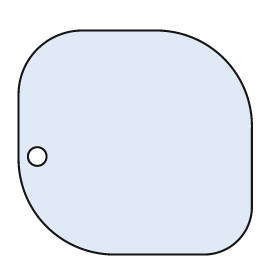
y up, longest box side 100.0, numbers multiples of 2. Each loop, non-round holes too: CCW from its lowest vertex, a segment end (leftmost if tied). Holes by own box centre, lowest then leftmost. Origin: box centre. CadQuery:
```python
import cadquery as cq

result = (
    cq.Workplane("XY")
    .moveTo(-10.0, -48.0)
    .lineTo(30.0, -48.0)
    .threePointArc((44.0, -42.0), (50.0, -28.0))
    .lineTo(50.0, 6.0)
    .threePointArc((38.0, 36.0), (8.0, 48.0))
    .lineTo(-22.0, 48.0)
    .threePointArc((-42.0, 40.0), (-50.0, 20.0))
    .lineTo(-50.0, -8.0)
    .threePointArc((-38.0, -36.0), (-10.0, -48.0))
    .close()
    .moveTo(-42.0, -6.0)
    .circle(4.0)
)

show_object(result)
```